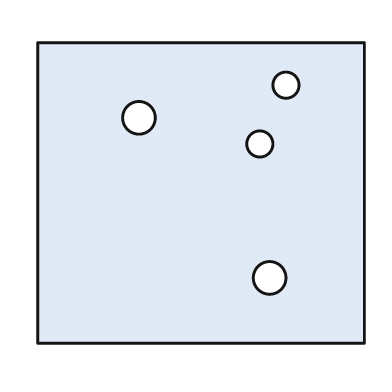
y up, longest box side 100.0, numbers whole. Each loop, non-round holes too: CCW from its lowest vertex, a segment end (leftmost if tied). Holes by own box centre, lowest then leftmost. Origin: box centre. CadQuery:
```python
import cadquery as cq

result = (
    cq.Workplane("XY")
    .moveTo(-50.0, -46.0)
    .lineTo(50.0, -46.0)
    .lineTo(50.0, 46.0)
    .lineTo(-50.0, 46.0)
    .close()
    .moveTo(21.0, -26.0)
    .circle(5.0)
    .moveTo(18.0, 15.0)
    .circle(4.0)
    .moveTo(-19.0, 23.0)
    .circle(5.0)
    .moveTo(26.0, 33.0)
    .circle(4.0)
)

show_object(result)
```